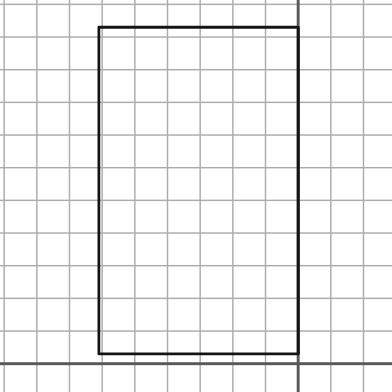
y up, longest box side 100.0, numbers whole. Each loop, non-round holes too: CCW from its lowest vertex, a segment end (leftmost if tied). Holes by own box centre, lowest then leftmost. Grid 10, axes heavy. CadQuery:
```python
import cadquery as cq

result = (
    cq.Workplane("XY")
    .moveTo(-61.0, 3.0)
    .lineTo(0.0, 3.0)
    .lineTo(0.0, 103.0)
    .lineTo(-61.0, 103.0)
    .close()
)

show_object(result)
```